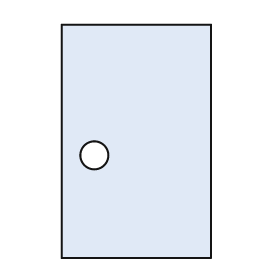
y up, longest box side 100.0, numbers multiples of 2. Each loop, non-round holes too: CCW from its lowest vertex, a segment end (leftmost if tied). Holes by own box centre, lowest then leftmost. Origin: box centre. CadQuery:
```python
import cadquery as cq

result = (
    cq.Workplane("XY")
    .moveTo(-32.0, -50.0)
    .lineTo(32.0, -50.0)
    .lineTo(32.0, 50.0)
    .lineTo(-32.0, 50.0)
    .close()
    .moveTo(-18.0, -6.0)
    .circle(6.0)
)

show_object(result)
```